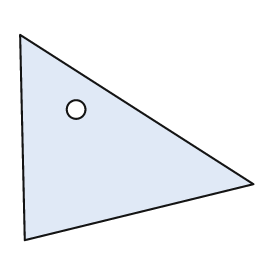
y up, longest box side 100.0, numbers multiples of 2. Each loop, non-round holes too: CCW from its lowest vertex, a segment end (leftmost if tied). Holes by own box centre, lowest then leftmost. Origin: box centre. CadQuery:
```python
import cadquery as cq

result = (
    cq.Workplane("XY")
    .moveTo(-48.0, -44.0)
    .lineTo(50.0, -20.0)
    .lineTo(-50.0, 44.0)
    .close()
    .moveTo(-26.0, 12.0)
    .circle(4.0)
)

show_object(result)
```